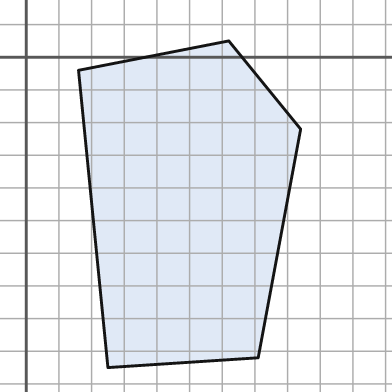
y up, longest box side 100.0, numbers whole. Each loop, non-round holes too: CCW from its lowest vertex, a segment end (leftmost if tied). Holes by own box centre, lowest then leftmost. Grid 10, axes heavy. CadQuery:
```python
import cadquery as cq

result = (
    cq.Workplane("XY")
    .moveTo(25.0, -95.0)
    .lineTo(71.0, -92.0)
    .lineTo(84.0, -22.0)
    .lineTo(62.0, 5.0)
    .lineTo(16.0, -4.0)
    .close()
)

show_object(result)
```